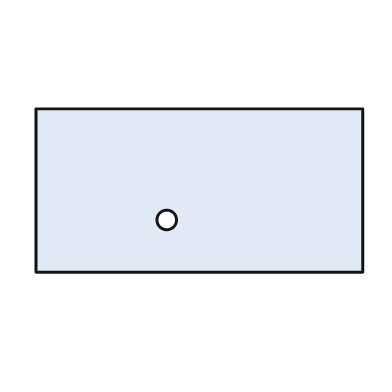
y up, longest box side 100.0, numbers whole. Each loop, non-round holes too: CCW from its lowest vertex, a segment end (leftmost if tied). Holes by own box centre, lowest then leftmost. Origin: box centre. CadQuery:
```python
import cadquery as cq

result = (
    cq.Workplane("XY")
    .moveTo(-50.0, -25.0)
    .lineTo(50.0, -25.0)
    .lineTo(50.0, 25.0)
    .lineTo(-50.0, 25.0)
    .close()
    .moveTo(-10.0, -9.0)
    .circle(3.0)
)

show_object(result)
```